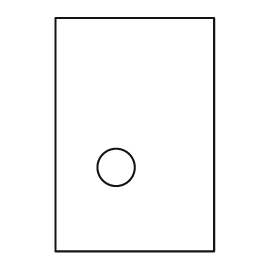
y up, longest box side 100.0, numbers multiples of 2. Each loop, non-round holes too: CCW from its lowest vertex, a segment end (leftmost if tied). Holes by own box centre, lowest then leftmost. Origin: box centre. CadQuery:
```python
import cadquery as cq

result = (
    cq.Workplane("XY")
    .moveTo(-34.0, -50.0)
    .lineTo(34.0, -50.0)
    .lineTo(34.0, 50.0)
    .lineTo(-34.0, 50.0)
    .close()
    .moveTo(-8.0, -14.0)
    .circle(8.0)
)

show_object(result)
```